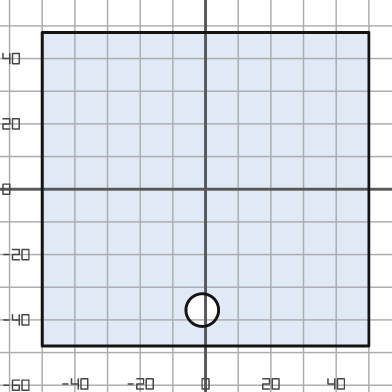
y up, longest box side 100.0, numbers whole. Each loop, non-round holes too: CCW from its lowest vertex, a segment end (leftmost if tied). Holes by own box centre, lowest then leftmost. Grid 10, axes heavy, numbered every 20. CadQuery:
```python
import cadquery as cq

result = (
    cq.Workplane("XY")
    .moveTo(-50.0, -48.0)
    .lineTo(50.0, -48.0)
    .lineTo(50.0, 48.0)
    .lineTo(-50.0, 48.0)
    .close()
    .moveTo(-1.0, -37.0)
    .circle(5.0)
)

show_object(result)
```